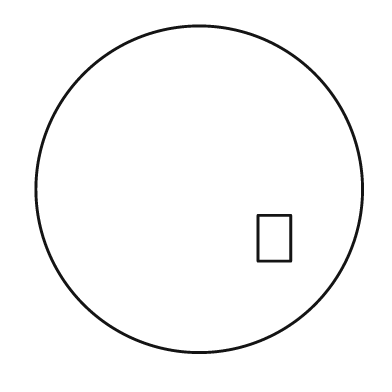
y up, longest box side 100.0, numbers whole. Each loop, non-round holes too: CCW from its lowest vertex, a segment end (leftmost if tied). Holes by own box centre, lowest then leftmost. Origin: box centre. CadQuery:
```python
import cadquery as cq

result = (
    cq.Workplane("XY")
    .moveTo(0.0, 0.0)
    .circle(50.0)
    .moveTo(18.0, -22.0)
    .lineTo(28.0, -22.0)
    .lineTo(28.0, -8.0)
    .lineTo(18.0, -8.0)
    .close()
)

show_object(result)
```